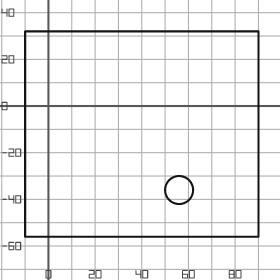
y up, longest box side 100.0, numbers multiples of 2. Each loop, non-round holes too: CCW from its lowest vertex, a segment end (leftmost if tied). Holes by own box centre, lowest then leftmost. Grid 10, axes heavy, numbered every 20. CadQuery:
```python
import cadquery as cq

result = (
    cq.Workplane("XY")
    .moveTo(-10.0, -56.0)
    .lineTo(90.0, -56.0)
    .lineTo(90.0, 32.0)
    .lineTo(-10.0, 32.0)
    .close()
    .moveTo(56.0, -36.0)
    .circle(6.0)
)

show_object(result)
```